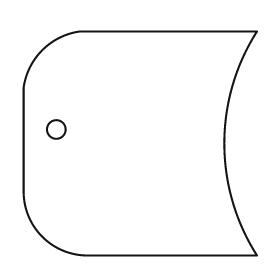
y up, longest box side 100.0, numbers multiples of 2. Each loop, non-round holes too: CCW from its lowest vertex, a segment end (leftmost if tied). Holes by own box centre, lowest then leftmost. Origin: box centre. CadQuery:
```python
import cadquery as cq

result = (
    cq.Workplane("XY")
    .moveTo(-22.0, -48.0)
    .lineTo(50.0, -48.0)
    .threePointArc((36.0, 0.0), (50.0, 48.0))
    .lineTo(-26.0, 48.0)
    .threePointArc((-42.0, 40.0), (-50.0, 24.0))
    .lineTo(-50.0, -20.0)
    .threePointArc((-42.0, -40.0), (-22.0, -48.0))
    .close()
    .moveTo(-36.0, 6.0)
    .circle(4.0)
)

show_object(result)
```